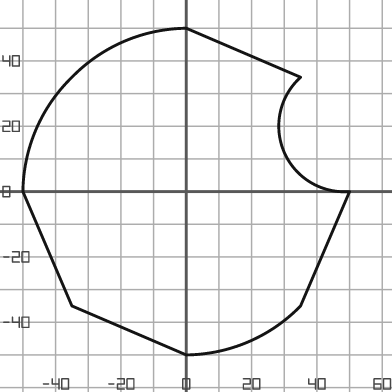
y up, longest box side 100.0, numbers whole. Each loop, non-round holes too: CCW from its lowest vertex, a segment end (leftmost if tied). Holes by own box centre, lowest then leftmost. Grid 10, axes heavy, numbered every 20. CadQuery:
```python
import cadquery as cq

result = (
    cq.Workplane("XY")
    .moveTo(0.0, -50.0)
    .threePointArc((19.0, -46.0), (35.0, -35.0))
    .lineTo(50.0, 0.0)
    .threePointArc((30.0, 12.0), (35.0, 35.0))
    .lineTo(0.0, 50.0)
    .threePointArc((-19.0, 46.0), (-35.0, 35.0))
    .threePointArc((-46.0, 19.0), (-50.0, 0.0))
    .lineTo(-35.0, -35.0)
    .close()
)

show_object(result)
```